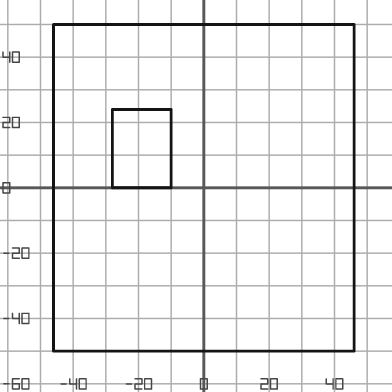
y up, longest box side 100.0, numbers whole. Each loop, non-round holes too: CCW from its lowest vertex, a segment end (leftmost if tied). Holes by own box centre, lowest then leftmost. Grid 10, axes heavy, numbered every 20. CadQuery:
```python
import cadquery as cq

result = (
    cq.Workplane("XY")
    .moveTo(-46.0, -50.0)
    .lineTo(46.0, -50.0)
    .lineTo(46.0, 50.0)
    .lineTo(-46.0, 50.0)
    .close()
    .moveTo(-28.0, 0.0)
    .lineTo(-10.0, 0.0)
    .lineTo(-10.0, 24.0)
    .lineTo(-28.0, 24.0)
    .close()
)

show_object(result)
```